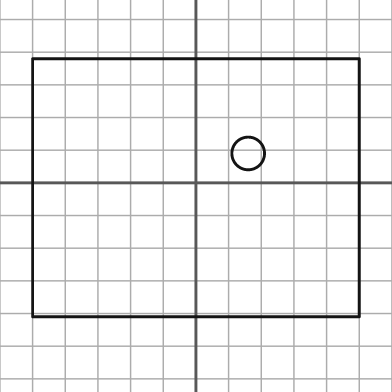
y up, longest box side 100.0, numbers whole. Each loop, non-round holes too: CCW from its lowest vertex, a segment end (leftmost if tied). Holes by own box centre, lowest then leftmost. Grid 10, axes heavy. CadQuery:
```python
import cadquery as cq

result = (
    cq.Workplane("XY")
    .moveTo(-50.0, -41.0)
    .lineTo(50.0, -41.0)
    .lineTo(50.0, 38.0)
    .lineTo(-50.0, 38.0)
    .close()
    .moveTo(16.0, 9.0)
    .circle(5.0)
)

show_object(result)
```